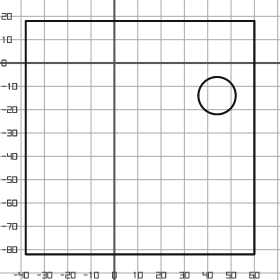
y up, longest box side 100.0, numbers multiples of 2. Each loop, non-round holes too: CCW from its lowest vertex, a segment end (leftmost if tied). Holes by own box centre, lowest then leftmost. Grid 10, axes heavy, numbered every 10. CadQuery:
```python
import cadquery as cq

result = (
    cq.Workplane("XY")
    .moveTo(-38.0, -82.0)
    .lineTo(60.0, -82.0)
    .lineTo(60.0, 18.0)
    .lineTo(-38.0, 18.0)
    .close()
    .moveTo(44.0, -14.0)
    .circle(8.0)
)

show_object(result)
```